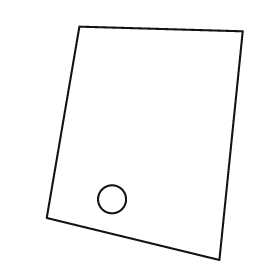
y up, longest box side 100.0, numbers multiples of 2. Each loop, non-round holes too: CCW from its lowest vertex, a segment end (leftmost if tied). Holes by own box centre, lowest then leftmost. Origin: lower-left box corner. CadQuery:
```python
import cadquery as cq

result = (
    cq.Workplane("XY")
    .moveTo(74.0, 0.0)
    .lineTo(84.0, 98.0)
    .lineTo(14.0, 100.0)
    .lineTo(0.0, 18.0)
    .close()
    .moveTo(28.0, 26.0)
    .circle(6.0)
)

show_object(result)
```